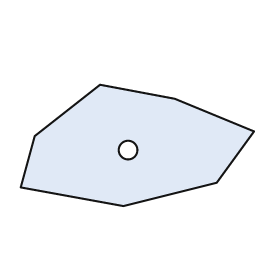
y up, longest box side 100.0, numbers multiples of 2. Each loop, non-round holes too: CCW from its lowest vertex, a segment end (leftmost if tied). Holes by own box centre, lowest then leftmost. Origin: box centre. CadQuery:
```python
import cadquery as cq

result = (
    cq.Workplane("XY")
    .moveTo(-6.0, -26.0)
    .lineTo(34.0, -16.0)
    .lineTo(50.0, 6.0)
    .lineTo(16.0, 20.0)
    .lineTo(-16.0, 26.0)
    .lineTo(-44.0, 4.0)
    .lineTo(-50.0, -18.0)
    .close()
    .moveTo(-4.0, -2.0)
    .circle(4.0)
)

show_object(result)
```